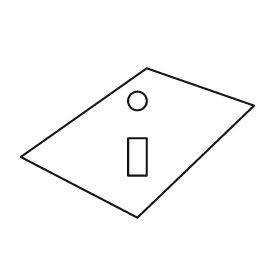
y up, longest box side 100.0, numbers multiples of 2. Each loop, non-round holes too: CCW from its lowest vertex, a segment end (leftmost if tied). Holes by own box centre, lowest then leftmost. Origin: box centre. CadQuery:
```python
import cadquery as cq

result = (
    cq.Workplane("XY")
    .moveTo(0.0, -32.0)
    .lineTo(50.0, 16.0)
    .lineTo(4.0, 32.0)
    .lineTo(-50.0, -6.0)
    .close()
    .moveTo(-4.0, -14.0)
    .lineTo(4.0, -14.0)
    .lineTo(4.0, 2.0)
    .lineTo(-4.0, 2.0)
    .close()
    .moveTo(0.0, 18.0)
    .circle(4.0)
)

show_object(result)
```